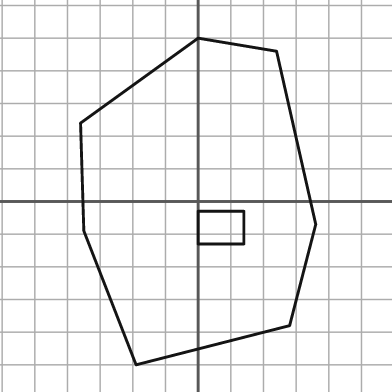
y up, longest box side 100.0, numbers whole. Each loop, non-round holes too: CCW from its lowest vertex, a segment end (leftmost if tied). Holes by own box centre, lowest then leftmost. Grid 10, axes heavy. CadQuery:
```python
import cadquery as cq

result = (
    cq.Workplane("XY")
    .moveTo(-19.0, -50.0)
    .lineTo(28.0, -38.0)
    .lineTo(36.0, -7.0)
    .lineTo(24.0, 46.0)
    .lineTo(0.0, 50.0)
    .lineTo(-36.0, 24.0)
    .lineTo(-35.0, -9.0)
    .close()
    .moveTo(0.0, -13.0)
    .lineTo(14.0, -13.0)
    .lineTo(14.0, -3.0)
    .lineTo(0.0, -3.0)
    .close()
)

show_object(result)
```